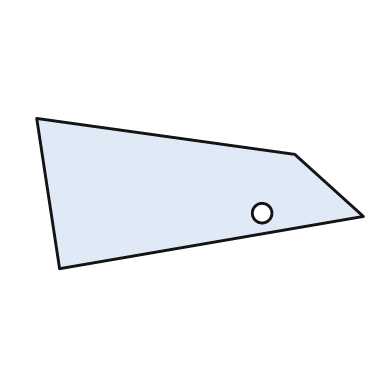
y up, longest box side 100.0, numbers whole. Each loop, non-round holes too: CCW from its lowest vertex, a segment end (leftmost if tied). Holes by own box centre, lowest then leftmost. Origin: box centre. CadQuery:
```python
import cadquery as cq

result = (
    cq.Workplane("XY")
    .moveTo(-43.0, -23.0)
    .lineTo(50.0, -7.0)
    .lineTo(29.0, 12.0)
    .lineTo(-50.0, 23.0)
    .close()
    .moveTo(19.0, -6.0)
    .circle(3.0)
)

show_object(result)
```